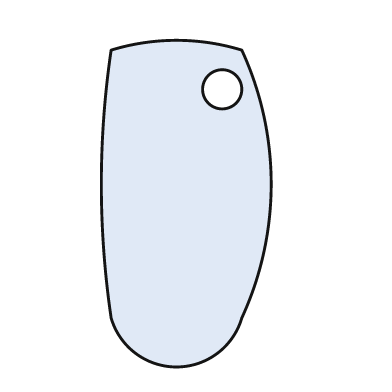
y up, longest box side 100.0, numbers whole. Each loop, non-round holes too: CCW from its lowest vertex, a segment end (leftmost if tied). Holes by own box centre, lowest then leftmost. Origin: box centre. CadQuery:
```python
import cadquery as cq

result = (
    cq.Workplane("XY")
    .moveTo(-23.0, -35.0)
    .threePointArc((-3.0, -50.0), (17.0, -35.0))
    .threePointArc((26.0, 6.0), (17.0, 47.0))
    .threePointArc((-3.0, 50.0), (-23.0, 47.0))
    .threePointArc((-26.0, 6.0), (-23.0, -35.0))
    .close()
    .moveTo(11.0, 35.0)
    .circle(6.0)
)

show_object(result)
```